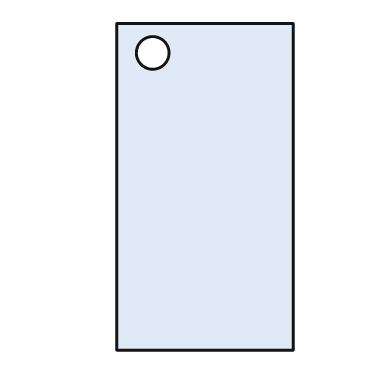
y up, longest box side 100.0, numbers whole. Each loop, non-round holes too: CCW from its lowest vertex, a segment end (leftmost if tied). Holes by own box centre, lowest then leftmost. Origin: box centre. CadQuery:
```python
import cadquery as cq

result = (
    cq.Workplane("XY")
    .moveTo(-27.0, -50.0)
    .lineTo(27.0, -50.0)
    .lineTo(27.0, 50.0)
    .lineTo(-27.0, 50.0)
    .close()
    .moveTo(-16.0, 41.0)
    .circle(5.0)
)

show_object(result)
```